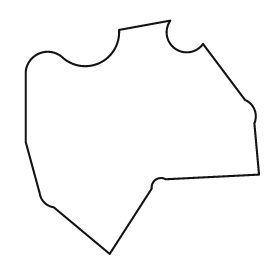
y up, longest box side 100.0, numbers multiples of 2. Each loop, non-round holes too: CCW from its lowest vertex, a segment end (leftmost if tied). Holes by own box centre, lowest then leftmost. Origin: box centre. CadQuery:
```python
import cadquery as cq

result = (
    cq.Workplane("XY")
    .moveTo(-14.0, -50.0)
    .lineTo(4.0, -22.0)
    .threePointArc((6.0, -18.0), (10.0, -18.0))
    .lineTo(50.0, -16.0)
    .lineTo(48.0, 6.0)
    .threePointArc((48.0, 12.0), (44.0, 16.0))
    .lineTo(26.0, 40.0)
    .threePointArc((14.0, 38.0), (12.0, 50.0))
    .lineTo(-10.0, 46.0)
    .threePointArc((-18.0, 32.0), (-34.0, 34.0))
    .threePointArc((-44.0, 36.0), (-50.0, 28.0))
    .lineTo(-50.0, -2.0)
    .lineTo(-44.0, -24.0)
    .threePointArc((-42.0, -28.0), (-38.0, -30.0))
    .close()
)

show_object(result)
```